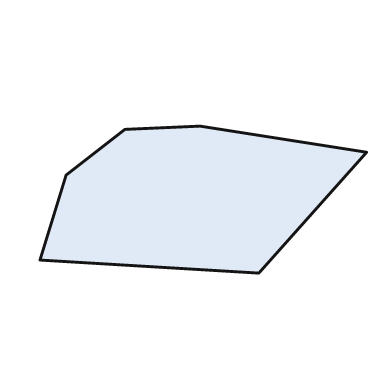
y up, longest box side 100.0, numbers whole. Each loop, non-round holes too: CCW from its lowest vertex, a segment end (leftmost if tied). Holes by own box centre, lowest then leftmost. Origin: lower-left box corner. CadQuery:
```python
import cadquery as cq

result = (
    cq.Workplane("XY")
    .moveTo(67.0, 0.0)
    .lineTo(100.0, 37.0)
    .lineTo(49.0, 45.0)
    .lineTo(26.0, 44.0)
    .lineTo(8.0, 30.0)
    .lineTo(0.0, 4.0)
    .close()
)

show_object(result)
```